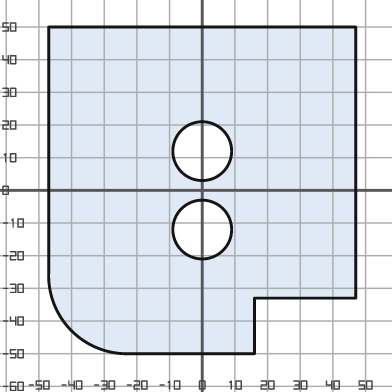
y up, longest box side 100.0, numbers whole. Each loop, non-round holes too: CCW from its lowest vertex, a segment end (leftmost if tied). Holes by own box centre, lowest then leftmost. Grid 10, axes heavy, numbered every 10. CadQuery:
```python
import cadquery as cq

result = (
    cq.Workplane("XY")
    .moveTo(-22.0, -50.0)
    .lineTo(16.0, -50.0)
    .lineTo(16.0, -33.0)
    .lineTo(47.0, -33.0)
    .lineTo(47.0, 50.0)
    .lineTo(-47.0, 50.0)
    .lineTo(-47.0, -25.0)
    .threePointArc((-40.0, -43.0), (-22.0, -50.0))
    .close()
    .moveTo(0.0, -12.0)
    .circle(9.0)
    .moveTo(0.0, 12.0)
    .circle(9.0)
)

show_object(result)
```